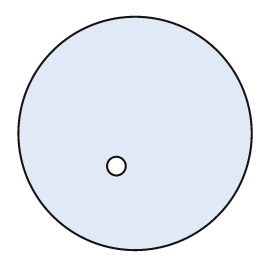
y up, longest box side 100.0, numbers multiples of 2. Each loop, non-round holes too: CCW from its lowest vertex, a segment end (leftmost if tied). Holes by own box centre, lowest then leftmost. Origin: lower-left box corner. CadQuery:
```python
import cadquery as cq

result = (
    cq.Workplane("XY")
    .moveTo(50.0, 50.0)
    .circle(50.0)
    .moveTo(42.0, 36.0)
    .circle(4.0)
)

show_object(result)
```